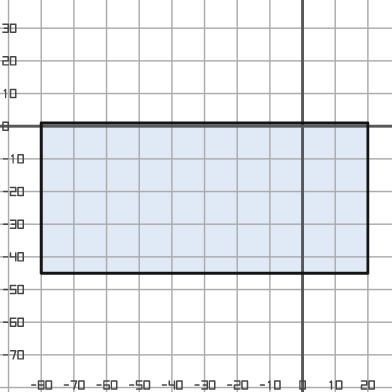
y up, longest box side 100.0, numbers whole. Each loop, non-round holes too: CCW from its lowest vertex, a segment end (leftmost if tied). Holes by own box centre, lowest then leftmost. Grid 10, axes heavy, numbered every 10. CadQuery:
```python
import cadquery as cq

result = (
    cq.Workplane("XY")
    .moveTo(-80.0, -45.0)
    .lineTo(20.0, -45.0)
    .lineTo(20.0, 1.0)
    .lineTo(-80.0, 1.0)
    .close()
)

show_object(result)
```